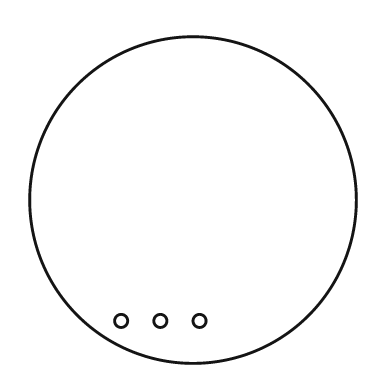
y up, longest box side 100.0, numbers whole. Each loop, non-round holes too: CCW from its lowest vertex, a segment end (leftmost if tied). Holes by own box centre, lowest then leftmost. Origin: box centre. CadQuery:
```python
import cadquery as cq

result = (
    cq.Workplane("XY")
    .moveTo(0.0, 0.0)
    .circle(50.0)
    .moveTo(-22.0, -37.0)
    .circle(2.0)
    .moveTo(-10.0, -37.0)
    .circle(2.0)
    .moveTo(2.0, -37.0)
    .circle(2.0)
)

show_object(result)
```